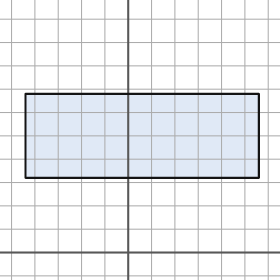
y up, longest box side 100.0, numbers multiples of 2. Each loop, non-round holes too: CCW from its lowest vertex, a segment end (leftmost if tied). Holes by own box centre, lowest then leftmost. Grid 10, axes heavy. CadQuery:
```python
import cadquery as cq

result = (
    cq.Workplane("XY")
    .moveTo(-44.0, 32.0)
    .lineTo(56.0, 32.0)
    .lineTo(56.0, 68.0)
    .lineTo(-44.0, 68.0)
    .close()
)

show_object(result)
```